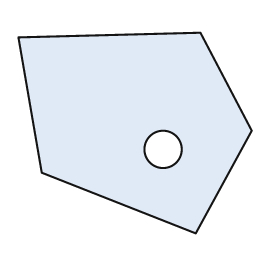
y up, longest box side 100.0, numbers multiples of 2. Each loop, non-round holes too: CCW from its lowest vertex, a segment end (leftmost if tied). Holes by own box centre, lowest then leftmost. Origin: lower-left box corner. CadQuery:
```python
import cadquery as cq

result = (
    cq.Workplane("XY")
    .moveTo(76.0, 0.0)
    .lineTo(100.0, 44.0)
    .lineTo(78.0, 86.0)
    .lineTo(0.0, 84.0)
    .lineTo(10.0, 26.0)
    .close()
    .moveTo(62.0, 36.0)
    .circle(8.0)
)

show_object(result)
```